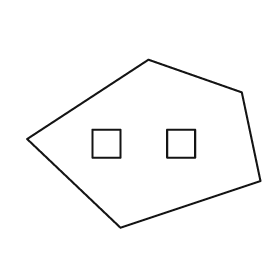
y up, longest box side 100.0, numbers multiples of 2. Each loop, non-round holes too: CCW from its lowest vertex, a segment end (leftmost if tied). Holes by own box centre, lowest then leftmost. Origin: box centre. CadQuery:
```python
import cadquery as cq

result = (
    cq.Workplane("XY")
    .moveTo(-10.0, -36.0)
    .lineTo(50.0, -16.0)
    .lineTo(42.0, 22.0)
    .lineTo(2.0, 36.0)
    .lineTo(-50.0, 2.0)
    .close()
    .moveTo(-22.0, -6.0)
    .lineTo(-10.0, -6.0)
    .lineTo(-10.0, 6.0)
    .lineTo(-22.0, 6.0)
    .close()
    .moveTo(10.0, -6.0)
    .lineTo(22.0, -6.0)
    .lineTo(22.0, 6.0)
    .lineTo(10.0, 6.0)
    .close()
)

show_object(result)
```